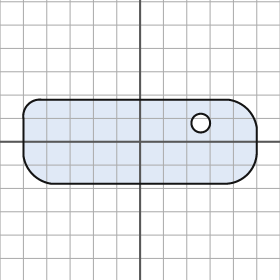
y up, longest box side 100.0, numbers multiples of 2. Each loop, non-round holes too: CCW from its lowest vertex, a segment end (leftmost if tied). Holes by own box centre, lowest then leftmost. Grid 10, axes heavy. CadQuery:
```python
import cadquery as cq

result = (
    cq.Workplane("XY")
    .moveTo(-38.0, -18.0)
    .lineTo(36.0, -18.0)
    .threePointArc((46.0, -14.0), (50.0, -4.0))
    .lineTo(50.0, 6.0)
    .threePointArc((46.0, 14.0), (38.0, 18.0))
    .lineTo(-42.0, 18.0)
    .threePointArc((-48.0, 16.0), (-50.0, 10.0))
    .lineTo(-50.0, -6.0)
    .threePointArc((-46.0, -14.0), (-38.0, -18.0))
    .close()
    .moveTo(26.0, 8.0)
    .circle(4.0)
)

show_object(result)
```